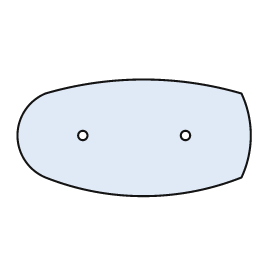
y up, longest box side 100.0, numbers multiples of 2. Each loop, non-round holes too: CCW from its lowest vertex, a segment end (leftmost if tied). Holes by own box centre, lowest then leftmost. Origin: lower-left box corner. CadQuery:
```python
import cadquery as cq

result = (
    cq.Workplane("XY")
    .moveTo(12.0, 8.0)
    .threePointArc((54.0, 0.0), (96.0, 8.0))
    .threePointArc((100.0, 26.0), (96.0, 44.0))
    .threePointArc((54.0, 50.0), (12.0, 44.0))
    .threePointArc((0.0, 26.0), (12.0, 8.0))
    .close()
    .moveTo(28.0, 26.0)
    .circle(2.0)
    .moveTo(72.0, 26.0)
    .circle(2.0)
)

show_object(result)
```